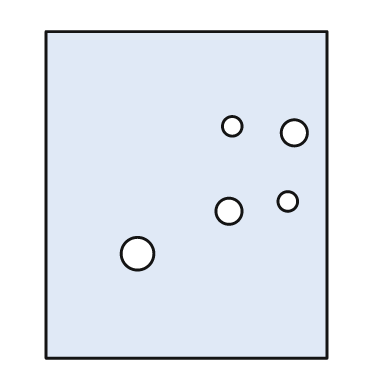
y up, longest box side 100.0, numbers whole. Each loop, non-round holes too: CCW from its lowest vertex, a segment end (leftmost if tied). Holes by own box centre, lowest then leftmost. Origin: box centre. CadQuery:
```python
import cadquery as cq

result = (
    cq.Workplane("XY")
    .moveTo(-43.0, -50.0)
    .lineTo(43.0, -50.0)
    .lineTo(43.0, 50.0)
    .lineTo(-43.0, 50.0)
    .close()
    .moveTo(-15.0, -18.0)
    .circle(5.0)
    .moveTo(13.0, -5.0)
    .circle(4.0)
    .moveTo(31.0, -2.0)
    .circle(3.0)
    .moveTo(33.0, 19.0)
    .circle(4.0)
    .moveTo(14.0, 21.0)
    .circle(3.0)
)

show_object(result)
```